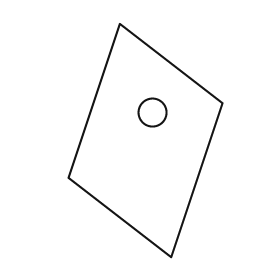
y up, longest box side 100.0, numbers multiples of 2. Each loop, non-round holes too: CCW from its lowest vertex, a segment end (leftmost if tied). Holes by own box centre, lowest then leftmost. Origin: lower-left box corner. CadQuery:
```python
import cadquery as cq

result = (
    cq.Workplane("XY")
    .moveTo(44.0, 0.0)
    .lineTo(66.0, 66.0)
    .lineTo(22.0, 100.0)
    .lineTo(0.0, 34.0)
    .close()
    .moveTo(36.0, 62.0)
    .circle(6.0)
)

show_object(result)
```